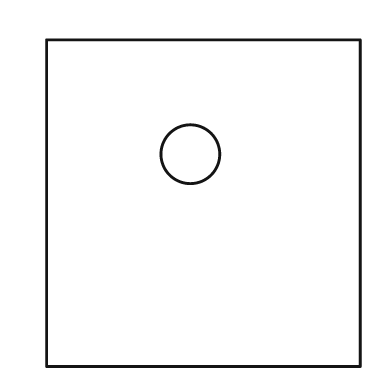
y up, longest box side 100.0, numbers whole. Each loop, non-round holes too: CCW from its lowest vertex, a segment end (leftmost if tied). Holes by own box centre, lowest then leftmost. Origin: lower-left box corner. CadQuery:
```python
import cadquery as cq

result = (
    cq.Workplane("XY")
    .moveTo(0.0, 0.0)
    .lineTo(96.0, 0.0)
    .lineTo(96.0, 100.0)
    .lineTo(0.0, 100.0)
    .close()
    .moveTo(44.0, 65.0)
    .circle(9.0)
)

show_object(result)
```